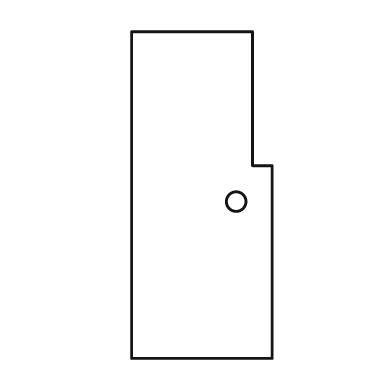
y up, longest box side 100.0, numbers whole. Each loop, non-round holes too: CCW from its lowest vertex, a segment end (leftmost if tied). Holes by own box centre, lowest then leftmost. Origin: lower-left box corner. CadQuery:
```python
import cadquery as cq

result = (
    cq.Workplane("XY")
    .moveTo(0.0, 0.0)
    .lineTo(43.0, 0.0)
    .lineTo(43.0, 59.0)
    .lineTo(37.0, 59.0)
    .lineTo(37.0, 100.0)
    .lineTo(0.0, 100.0)
    .close()
    .moveTo(32.0, 48.0)
    .circle(3.0)
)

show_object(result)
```